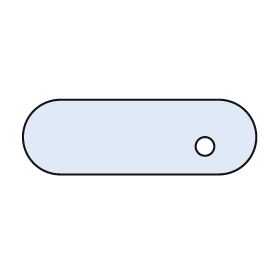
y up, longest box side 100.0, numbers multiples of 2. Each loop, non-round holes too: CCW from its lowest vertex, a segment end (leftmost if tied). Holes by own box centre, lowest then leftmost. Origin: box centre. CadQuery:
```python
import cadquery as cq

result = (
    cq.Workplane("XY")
    .moveTo(-34.0, -16.0)
    .lineTo(34.0, -16.0)
    .threePointArc((50.0, 0.0), (34.0, 16.0))
    .lineTo(-34.0, 16.0)
    .threePointArc((-50.0, 0.0), (-34.0, -16.0))
    .close()
    .moveTo(28.0, -4.0)
    .circle(4.0)
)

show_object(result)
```